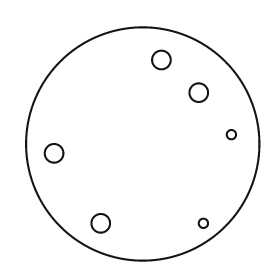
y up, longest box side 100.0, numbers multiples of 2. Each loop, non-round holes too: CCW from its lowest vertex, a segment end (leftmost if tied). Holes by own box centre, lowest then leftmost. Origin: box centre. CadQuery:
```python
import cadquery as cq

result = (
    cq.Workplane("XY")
    .moveTo(0.0, 0.0)
    .circle(50.0)
    .moveTo(-18.0, -34.0)
    .circle(4.0)
    .moveTo(26.0, -34.0)
    .circle(2.0)
    .moveTo(-38.0, -4.0)
    .circle(4.0)
    .moveTo(38.0, 4.0)
    .circle(2.0)
    .moveTo(24.0, 22.0)
    .circle(4.0)
    .moveTo(8.0, 36.0)
    .circle(4.0)
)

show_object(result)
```